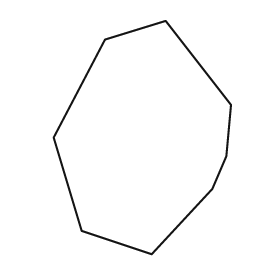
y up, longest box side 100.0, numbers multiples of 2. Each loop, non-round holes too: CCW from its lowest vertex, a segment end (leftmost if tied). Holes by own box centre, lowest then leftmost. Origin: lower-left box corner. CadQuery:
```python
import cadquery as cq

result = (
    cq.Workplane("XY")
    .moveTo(42.0, 0.0)
    .lineTo(68.0, 28.0)
    .lineTo(74.0, 42.0)
    .lineTo(76.0, 64.0)
    .lineTo(48.0, 100.0)
    .lineTo(22.0, 92.0)
    .lineTo(0.0, 50.0)
    .lineTo(12.0, 10.0)
    .close()
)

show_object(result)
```